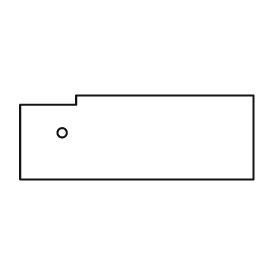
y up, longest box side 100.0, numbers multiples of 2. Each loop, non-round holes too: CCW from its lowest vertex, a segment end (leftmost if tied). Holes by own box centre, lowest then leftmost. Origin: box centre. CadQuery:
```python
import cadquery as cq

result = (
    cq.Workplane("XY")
    .moveTo(-50.0, -18.0)
    .lineTo(50.0, -18.0)
    .lineTo(50.0, 18.0)
    .lineTo(-26.0, 18.0)
    .lineTo(-26.0, 14.0)
    .lineTo(-50.0, 14.0)
    .close()
    .moveTo(-32.0, 2.0)
    .circle(2.0)
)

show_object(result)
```